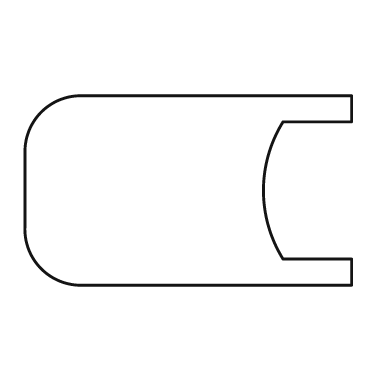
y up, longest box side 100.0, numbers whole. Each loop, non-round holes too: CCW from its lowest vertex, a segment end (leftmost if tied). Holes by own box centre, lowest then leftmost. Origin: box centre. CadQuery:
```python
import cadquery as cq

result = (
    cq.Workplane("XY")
    .moveTo(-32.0, -29.0)
    .lineTo(50.0, -29.0)
    .lineTo(50.0, -21.0)
    .lineTo(29.0, -21.0)
    .threePointArc((23.0, 0.0), (29.0, 21.0))
    .lineTo(50.0, 21.0)
    .lineTo(50.0, 29.0)
    .lineTo(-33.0, 29.0)
    .threePointArc((-45.0, 24.0), (-50.0, 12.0))
    .lineTo(-50.0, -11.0)
    .threePointArc((-45.0, -24.0), (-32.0, -29.0))
    .close()
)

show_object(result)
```